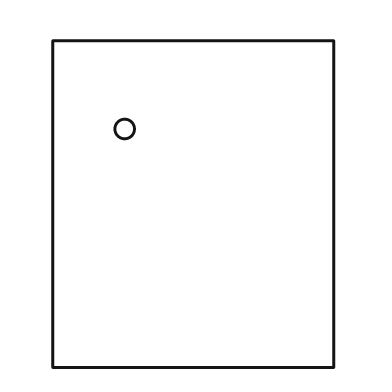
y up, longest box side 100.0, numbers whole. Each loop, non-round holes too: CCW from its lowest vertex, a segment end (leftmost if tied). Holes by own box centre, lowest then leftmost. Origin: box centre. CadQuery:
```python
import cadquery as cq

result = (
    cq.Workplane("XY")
    .moveTo(-43.0, -50.0)
    .lineTo(43.0, -50.0)
    .lineTo(43.0, 50.0)
    .lineTo(-43.0, 50.0)
    .close()
    .moveTo(-21.0, 23.0)
    .circle(3.0)
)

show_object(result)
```